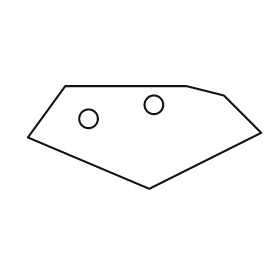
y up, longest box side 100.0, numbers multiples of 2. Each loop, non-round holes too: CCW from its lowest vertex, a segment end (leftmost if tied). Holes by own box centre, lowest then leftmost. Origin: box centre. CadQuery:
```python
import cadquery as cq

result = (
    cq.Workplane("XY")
    .moveTo(2.0, -22.0)
    .lineTo(50.0, 2.0)
    .lineTo(34.0, 18.0)
    .lineTo(18.0, 22.0)
    .lineTo(-34.0, 22.0)
    .lineTo(-50.0, 0.0)
    .close()
    .moveTo(-24.0, 8.0)
    .circle(4.0)
    .moveTo(4.0, 14.0)
    .circle(4.0)
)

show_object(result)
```